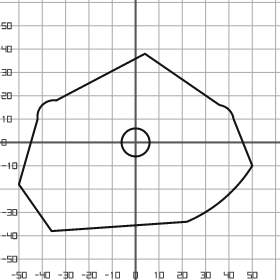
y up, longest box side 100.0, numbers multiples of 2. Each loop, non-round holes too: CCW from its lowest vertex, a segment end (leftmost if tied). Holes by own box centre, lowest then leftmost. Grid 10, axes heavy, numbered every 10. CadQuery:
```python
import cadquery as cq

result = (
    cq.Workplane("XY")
    .moveTo(-36.0, -38.0)
    .lineTo(22.0, -34.0)
    .threePointArc((38.0, -24.0), (50.0, -10.0))
    .lineTo(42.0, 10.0)
    .threePointArc((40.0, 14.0), (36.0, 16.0))
    .lineTo(4.0, 38.0)
    .lineTo(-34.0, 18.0)
    .threePointArc((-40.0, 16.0), (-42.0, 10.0))
    .lineTo(-50.0, -18.0)
    .close()
    .moveTo(0.0, 0.0)
    .circle(6.0)
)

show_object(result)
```